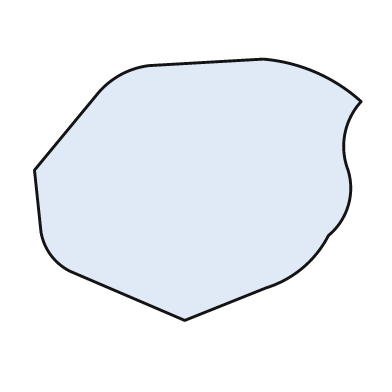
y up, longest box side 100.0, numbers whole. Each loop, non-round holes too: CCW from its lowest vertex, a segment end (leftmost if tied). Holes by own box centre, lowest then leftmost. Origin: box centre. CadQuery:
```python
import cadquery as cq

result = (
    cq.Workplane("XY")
    .moveTo(-4.0, -40.0)
    .lineTo(21.0, -30.0)
    .threePointArc((32.0, -24.0), (40.0, -14.0))
    .threePointArc((46.0, -5.0), (46.0, 6.0))
    .threePointArc((45.0, 17.0), (50.0, 27.0))
    .threePointArc((36.0, 36.0), (20.0, 40.0))
    .lineTo(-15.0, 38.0)
    .threePointArc((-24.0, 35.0), (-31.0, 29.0))
    .lineTo(-50.0, 6.0)
    .lineTo(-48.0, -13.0)
    .threePointArc((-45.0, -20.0), (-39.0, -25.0))
    .close()
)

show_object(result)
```